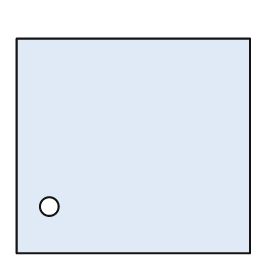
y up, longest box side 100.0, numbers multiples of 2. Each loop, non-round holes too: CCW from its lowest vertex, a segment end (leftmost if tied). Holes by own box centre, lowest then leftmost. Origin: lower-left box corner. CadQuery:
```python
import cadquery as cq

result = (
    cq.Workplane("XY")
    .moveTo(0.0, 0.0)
    .lineTo(100.0, 0.0)
    .lineTo(100.0, 92.0)
    .lineTo(0.0, 92.0)
    .close()
    .moveTo(14.0, 20.0)
    .circle(4.0)
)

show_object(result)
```